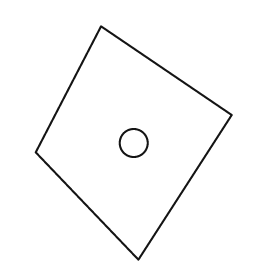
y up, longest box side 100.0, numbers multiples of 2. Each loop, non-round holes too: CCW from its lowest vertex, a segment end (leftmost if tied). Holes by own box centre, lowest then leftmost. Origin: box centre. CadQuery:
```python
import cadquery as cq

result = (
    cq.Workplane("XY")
    .moveTo(2.0, -50.0)
    .lineTo(42.0, 12.0)
    .lineTo(-14.0, 50.0)
    .lineTo(-42.0, -4.0)
    .close()
    .moveTo(0.0, 0.0)
    .circle(6.0)
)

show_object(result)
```